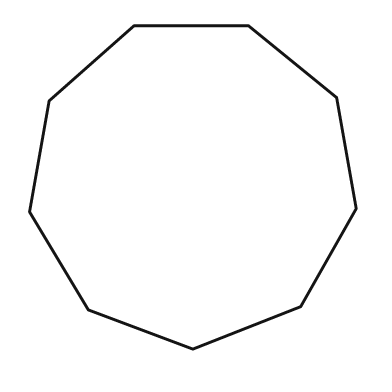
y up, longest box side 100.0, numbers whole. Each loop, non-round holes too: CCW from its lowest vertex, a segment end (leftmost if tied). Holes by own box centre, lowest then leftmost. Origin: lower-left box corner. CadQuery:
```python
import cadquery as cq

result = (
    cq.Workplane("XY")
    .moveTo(50.0, 0.0)
    .lineTo(83.0, 13.0)
    .lineTo(100.0, 43.0)
    .lineTo(94.0, 77.0)
    .lineTo(67.0, 99.0)
    .lineTo(32.0, 99.0)
    .lineTo(6.0, 76.0)
    .lineTo(0.0, 42.0)
    .lineTo(18.0, 12.0)
    .close()
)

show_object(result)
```